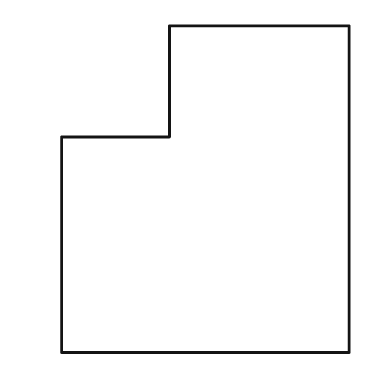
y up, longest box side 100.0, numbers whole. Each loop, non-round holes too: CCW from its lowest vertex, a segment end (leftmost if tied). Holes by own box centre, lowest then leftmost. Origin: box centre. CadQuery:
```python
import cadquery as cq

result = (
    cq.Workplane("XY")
    .moveTo(-44.0, -50.0)
    .lineTo(44.0, -50.0)
    .lineTo(44.0, 50.0)
    .lineTo(-11.0, 50.0)
    .lineTo(-11.0, 16.0)
    .lineTo(-44.0, 16.0)
    .close()
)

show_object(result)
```